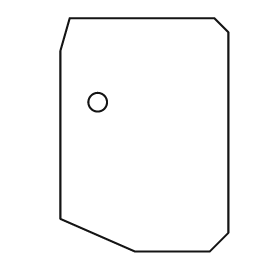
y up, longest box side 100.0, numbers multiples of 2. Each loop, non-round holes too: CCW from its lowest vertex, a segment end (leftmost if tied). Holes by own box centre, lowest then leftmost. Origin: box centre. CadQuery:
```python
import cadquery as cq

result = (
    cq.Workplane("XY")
    .moveTo(-4.0, -50.0)
    .lineTo(28.0, -50.0)
    .lineTo(36.0, -42.0)
    .lineTo(36.0, 44.0)
    .lineTo(30.0, 50.0)
    .lineTo(-32.0, 50.0)
    .lineTo(-36.0, 36.0)
    .lineTo(-36.0, -36.0)
    .close()
    .moveTo(-20.0, 14.0)
    .circle(4.0)
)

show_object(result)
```